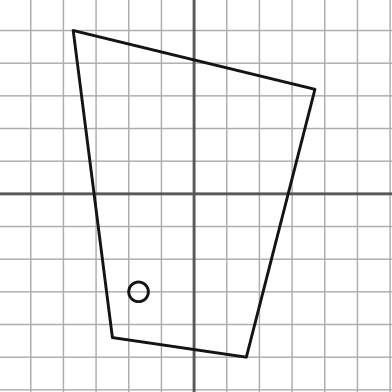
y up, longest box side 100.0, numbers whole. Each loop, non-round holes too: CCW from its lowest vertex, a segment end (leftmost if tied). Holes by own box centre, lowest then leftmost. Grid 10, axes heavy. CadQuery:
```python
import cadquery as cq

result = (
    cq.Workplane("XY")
    .moveTo(16.0, -50.0)
    .lineTo(37.0, 32.0)
    .lineTo(-37.0, 50.0)
    .lineTo(-25.0, -44.0)
    .close()
    .moveTo(-17.0, -30.0)
    .circle(3.0)
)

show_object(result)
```